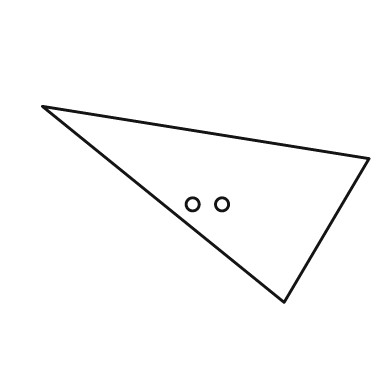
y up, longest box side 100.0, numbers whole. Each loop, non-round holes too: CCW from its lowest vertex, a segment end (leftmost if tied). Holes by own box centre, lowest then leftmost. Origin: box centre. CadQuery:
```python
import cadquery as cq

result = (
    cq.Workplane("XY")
    .moveTo(24.0, -30.0)
    .lineTo(50.0, 14.0)
    .lineTo(-50.0, 30.0)
    .close()
    .moveTo(-4.0, 0.0)
    .circle(2.0)
    .moveTo(5.0, 0.0)
    .circle(2.0)
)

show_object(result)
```